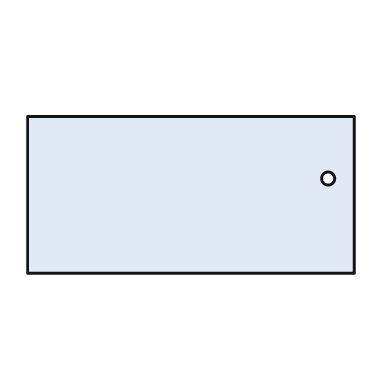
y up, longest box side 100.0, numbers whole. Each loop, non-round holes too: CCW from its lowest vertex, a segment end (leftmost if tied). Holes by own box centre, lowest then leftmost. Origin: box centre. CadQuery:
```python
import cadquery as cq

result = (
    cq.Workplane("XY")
    .moveTo(-50.0, -24.0)
    .lineTo(50.0, -24.0)
    .lineTo(50.0, 24.0)
    .lineTo(-50.0, 24.0)
    .close()
    .moveTo(42.0, 5.0)
    .circle(2.0)
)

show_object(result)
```